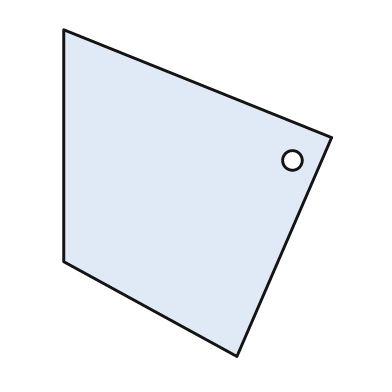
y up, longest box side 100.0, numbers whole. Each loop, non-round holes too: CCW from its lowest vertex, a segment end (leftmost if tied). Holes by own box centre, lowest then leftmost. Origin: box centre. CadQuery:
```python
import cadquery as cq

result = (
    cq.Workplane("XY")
    .moveTo(12.0, -50.0)
    .lineTo(41.0, 17.0)
    .lineTo(-41.0, 50.0)
    .lineTo(-41.0, -21.0)
    .close()
    .moveTo(29.0, 10.0)
    .circle(3.0)
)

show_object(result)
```